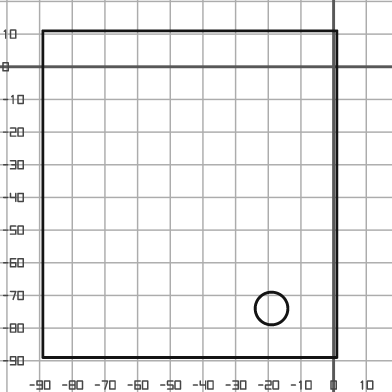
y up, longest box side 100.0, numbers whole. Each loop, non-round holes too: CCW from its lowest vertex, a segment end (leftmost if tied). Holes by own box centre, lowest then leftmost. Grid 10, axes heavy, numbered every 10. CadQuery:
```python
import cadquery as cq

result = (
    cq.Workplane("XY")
    .moveTo(-89.0, -89.0)
    .lineTo(1.0, -89.0)
    .lineTo(1.0, 11.0)
    .lineTo(-89.0, 11.0)
    .close()
    .moveTo(-19.0, -74.0)
    .circle(5.0)
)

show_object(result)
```